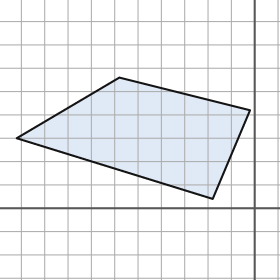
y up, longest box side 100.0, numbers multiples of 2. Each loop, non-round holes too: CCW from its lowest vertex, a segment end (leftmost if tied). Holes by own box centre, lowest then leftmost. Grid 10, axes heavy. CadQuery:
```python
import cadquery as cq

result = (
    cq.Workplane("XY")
    .moveTo(-18.0, 4.0)
    .lineTo(-2.0, 42.0)
    .lineTo(-58.0, 56.0)
    .lineTo(-102.0, 30.0)
    .close()
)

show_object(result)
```